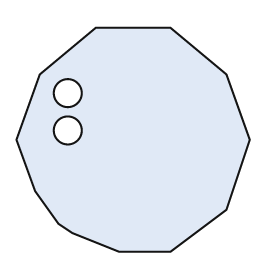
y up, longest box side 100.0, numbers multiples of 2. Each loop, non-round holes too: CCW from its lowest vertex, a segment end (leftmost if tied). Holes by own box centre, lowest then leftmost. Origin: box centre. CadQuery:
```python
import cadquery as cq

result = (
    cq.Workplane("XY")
    .moveTo(-6.0, -48.0)
    .lineTo(16.0, -48.0)
    .lineTo(40.0, -30.0)
    .lineTo(50.0, 0.0)
    .lineTo(40.0, 28.0)
    .lineTo(16.0, 48.0)
    .lineTo(-16.0, 48.0)
    .lineTo(-40.0, 28.0)
    .lineTo(-50.0, 0.0)
    .lineTo(-42.0, -22.0)
    .lineTo(-32.0, -36.0)
    .lineTo(-26.0, -40.0)
    .close()
    .moveTo(-28.0, 4.0)
    .circle(6.0)
    .moveTo(-28.0, 20.0)
    .circle(6.0)
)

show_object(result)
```